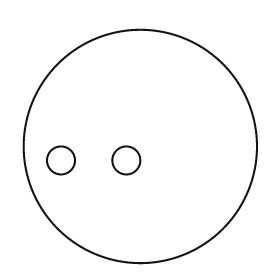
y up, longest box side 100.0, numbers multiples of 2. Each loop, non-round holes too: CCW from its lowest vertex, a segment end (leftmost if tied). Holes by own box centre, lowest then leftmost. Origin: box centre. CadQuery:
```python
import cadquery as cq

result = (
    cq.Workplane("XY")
    .moveTo(0.0, 0.0)
    .circle(50.0)
    .moveTo(-34.0, -6.0)
    .circle(6.0)
    .moveTo(-6.0, -6.0)
    .circle(6.0)
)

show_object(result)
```